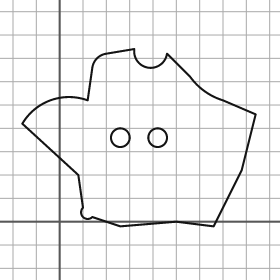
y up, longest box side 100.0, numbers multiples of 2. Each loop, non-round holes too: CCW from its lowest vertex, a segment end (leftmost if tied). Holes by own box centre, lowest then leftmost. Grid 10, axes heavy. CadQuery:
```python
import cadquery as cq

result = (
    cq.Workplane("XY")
    .moveTo(26.0, -2.0)
    .lineTo(50.0, 0.0)
    .lineTo(66.0, -2.0)
    .lineTo(78.0, 22.0)
    .lineTo(84.0, 46.0)
    .lineTo(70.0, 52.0)
    .threePointArc((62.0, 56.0), (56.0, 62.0))
    .lineTo(46.0, 72.0)
    .threePointArc((38.0, 66.0), (32.0, 74.0))
    .lineTo(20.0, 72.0)
    .threePointArc((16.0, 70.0), (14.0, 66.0))
    .lineTo(12.0, 52.0)
    .threePointArc((-4.0, 52.0), (-16.0, 42.0))
    .lineTo(8.0, 20.0)
    .lineTo(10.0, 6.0)
    .threePointArc((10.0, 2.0), (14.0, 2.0))
    .close()
    .moveTo(26.0, 36.0)
    .circle(4.0)
    .moveTo(42.0, 36.0)
    .circle(4.0)
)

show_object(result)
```